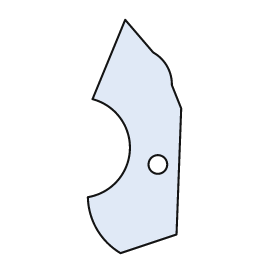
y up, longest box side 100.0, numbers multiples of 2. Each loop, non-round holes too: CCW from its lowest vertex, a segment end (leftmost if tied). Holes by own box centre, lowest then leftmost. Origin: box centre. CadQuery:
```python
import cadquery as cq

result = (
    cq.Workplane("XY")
    .moveTo(-6.0, -50.0)
    .lineTo(18.0, -42.0)
    .lineTo(20.0, 12.0)
    .lineTo(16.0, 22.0)
    .threePointArc((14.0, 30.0), (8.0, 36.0))
    .lineTo(-4.0, 50.0)
    .lineTo(-18.0, 16.0)
    .threePointArc((-2.0, -6.0), (-20.0, -26.0))
    .threePointArc((-16.0, -40.0), (-6.0, -50.0))
    .close()
    .moveTo(10.0, -12.0)
    .circle(4.0)
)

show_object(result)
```